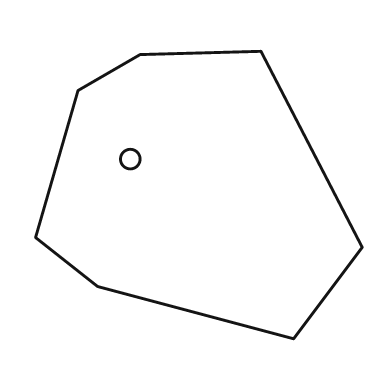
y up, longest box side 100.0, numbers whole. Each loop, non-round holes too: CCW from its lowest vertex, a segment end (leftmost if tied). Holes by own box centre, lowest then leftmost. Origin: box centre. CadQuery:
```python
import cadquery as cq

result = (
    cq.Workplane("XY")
    .moveTo(29.0, -44.0)
    .lineTo(50.0, -16.0)
    .lineTo(19.0, 44.0)
    .lineTo(-18.0, 43.0)
    .lineTo(-37.0, 32.0)
    .lineTo(-50.0, -13.0)
    .lineTo(-31.0, -28.0)
    .close()
    .moveTo(-21.0, 11.0)
    .circle(3.0)
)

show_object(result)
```